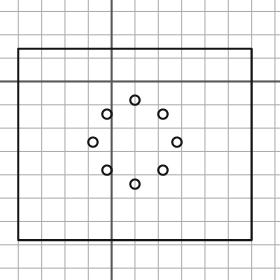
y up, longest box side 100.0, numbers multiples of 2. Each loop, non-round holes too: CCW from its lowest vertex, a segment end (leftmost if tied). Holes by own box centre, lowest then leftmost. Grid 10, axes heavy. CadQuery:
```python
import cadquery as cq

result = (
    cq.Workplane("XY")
    .moveTo(-40.0, -68.0)
    .lineTo(60.0, -68.0)
    .lineTo(60.0, 14.0)
    .lineTo(-40.0, 14.0)
    .close()
    .moveTo(10.0, -44.0)
    .circle(2.0)
    .moveTo(-2.0, -38.0)
    .circle(2.0)
    .moveTo(22.0, -38.0)
    .circle(2.0)
    .moveTo(-8.0, -26.0)
    .circle(2.0)
    .moveTo(28.0, -26.0)
    .circle(2.0)
    .moveTo(-2.0, -14.0)
    .circle(2.0)
    .moveTo(22.0, -14.0)
    .circle(2.0)
    .moveTo(10.0, -8.0)
    .circle(2.0)
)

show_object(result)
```